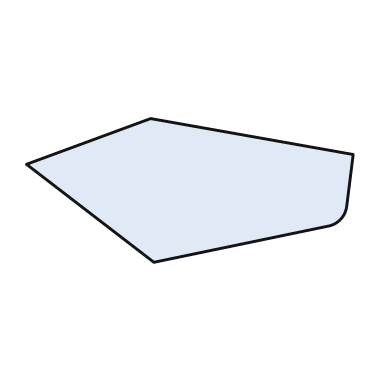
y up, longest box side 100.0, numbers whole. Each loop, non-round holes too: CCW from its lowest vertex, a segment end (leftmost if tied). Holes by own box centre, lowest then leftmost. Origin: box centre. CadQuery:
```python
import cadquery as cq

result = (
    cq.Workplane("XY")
    .moveTo(-11.0, -22.0)
    .lineTo(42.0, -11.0)
    .threePointArc((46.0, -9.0), (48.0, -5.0))
    .lineTo(50.0, 11.0)
    .lineTo(-12.0, 22.0)
    .lineTo(-50.0, 8.0)
    .close()
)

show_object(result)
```